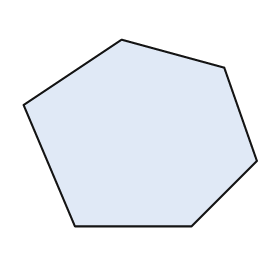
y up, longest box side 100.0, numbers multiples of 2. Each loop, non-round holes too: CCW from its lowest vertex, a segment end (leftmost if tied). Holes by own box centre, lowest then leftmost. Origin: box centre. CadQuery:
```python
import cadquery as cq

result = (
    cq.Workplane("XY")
    .moveTo(-28.0, -40.0)
    .lineTo(22.0, -40.0)
    .lineTo(50.0, -12.0)
    .lineTo(36.0, 28.0)
    .lineTo(-8.0, 40.0)
    .lineTo(-50.0, 12.0)
    .close()
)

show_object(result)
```